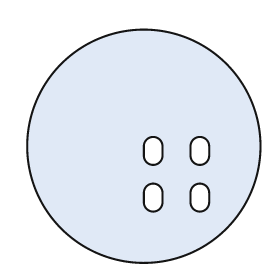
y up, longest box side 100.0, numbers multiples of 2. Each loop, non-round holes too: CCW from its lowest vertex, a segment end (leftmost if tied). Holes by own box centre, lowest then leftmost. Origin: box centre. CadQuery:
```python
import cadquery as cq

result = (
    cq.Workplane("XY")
    .moveTo(0.0, 0.0)
    .circle(50.0)
    .moveTo(0.0, -24.0)
    .threePointArc((4.0, -28.0), (8.0, -24.0))
    .lineTo(8.0, -20.0)
    .threePointArc((4.0, -16.0), (0.0, -20.0))
    .close()
    .moveTo(20.0, -24.0)
    .threePointArc((24.0, -28.0), (28.0, -24.0))
    .lineTo(28.0, -20.0)
    .threePointArc((24.0, -16.0), (20.0, -20.0))
    .close()
    .moveTo(0.0, -4.0)
    .threePointArc((4.0, -8.0), (8.0, -4.0))
    .lineTo(8.0, 0.0)
    .threePointArc((4.0, 4.0), (0.0, 0.0))
    .close()
    .moveTo(20.0, -4.0)
    .threePointArc((24.0, -8.0), (28.0, -4.0))
    .lineTo(28.0, 0.0)
    .threePointArc((24.0, 4.0), (20.0, 0.0))
    .close()
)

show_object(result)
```